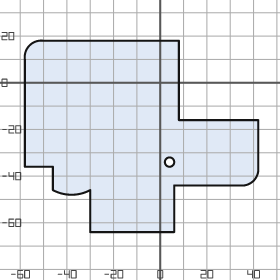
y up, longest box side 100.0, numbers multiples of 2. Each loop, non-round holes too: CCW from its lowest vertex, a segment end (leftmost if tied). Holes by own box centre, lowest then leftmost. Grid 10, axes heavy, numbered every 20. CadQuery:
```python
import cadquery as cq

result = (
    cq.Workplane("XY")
    .moveTo(-30.0, -64.0)
    .lineTo(6.0, -64.0)
    .lineTo(6.0, -44.0)
    .lineTo(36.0, -44.0)
    .threePointArc((40.0, -42.0), (42.0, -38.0))
    .lineTo(42.0, -16.0)
    .lineTo(8.0, -16.0)
    .lineTo(8.0, 18.0)
    .lineTo(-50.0, 18.0)
    .threePointArc((-56.0, 16.0), (-58.0, 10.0))
    .lineTo(-58.0, -36.0)
    .lineTo(-46.0, -36.0)
    .lineTo(-46.0, -46.0)
    .threePointArc((-38.0, -48.0), (-30.0, -46.0))
    .close()
    .moveTo(4.0, -34.0)
    .circle(2.0)
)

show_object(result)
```